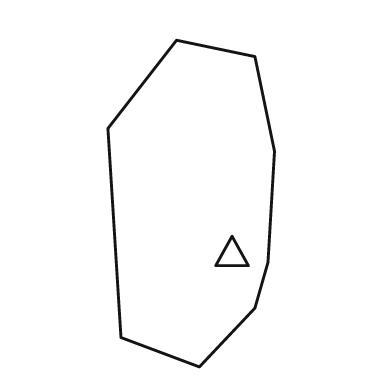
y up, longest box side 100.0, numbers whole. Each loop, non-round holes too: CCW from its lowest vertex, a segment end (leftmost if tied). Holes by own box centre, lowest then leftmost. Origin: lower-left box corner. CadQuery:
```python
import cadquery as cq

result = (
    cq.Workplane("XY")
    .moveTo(28.0, 0.0)
    .lineTo(45.0, 18.0)
    .lineTo(49.0, 32.0)
    .lineTo(51.0, 66.0)
    .lineTo(45.0, 95.0)
    .lineTo(21.0, 100.0)
    .lineTo(0.0, 73.0)
    .lineTo(4.0, 9.0)
    .close()
    .moveTo(33.0, 31.0)
    .lineTo(43.0, 31.0)
    .lineTo(38.0, 40.0)
    .close()
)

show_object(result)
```